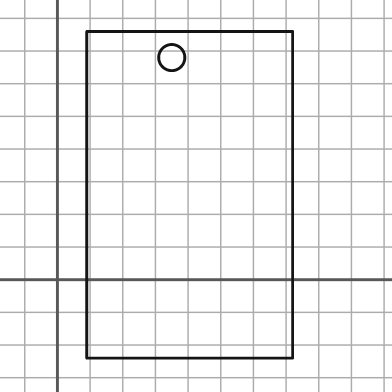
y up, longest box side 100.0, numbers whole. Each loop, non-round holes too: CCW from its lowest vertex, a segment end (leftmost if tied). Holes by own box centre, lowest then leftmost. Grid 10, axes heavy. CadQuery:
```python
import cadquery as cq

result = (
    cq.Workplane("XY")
    .moveTo(9.0, -24.0)
    .lineTo(72.0, -24.0)
    .lineTo(72.0, 76.0)
    .lineTo(9.0, 76.0)
    .close()
    .moveTo(35.0, 68.0)
    .circle(4.0)
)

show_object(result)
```